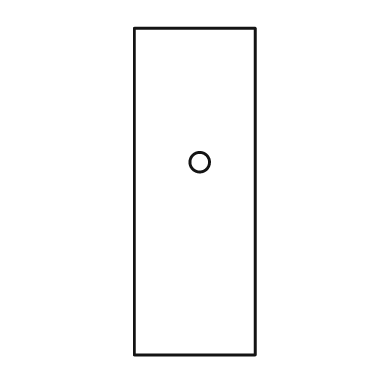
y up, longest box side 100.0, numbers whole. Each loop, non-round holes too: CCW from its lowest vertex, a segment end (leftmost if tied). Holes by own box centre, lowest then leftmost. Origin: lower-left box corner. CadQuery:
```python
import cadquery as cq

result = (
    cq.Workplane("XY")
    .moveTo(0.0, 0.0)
    .lineTo(37.0, 0.0)
    .lineTo(37.0, 100.0)
    .lineTo(0.0, 100.0)
    .close()
    .moveTo(20.0, 59.0)
    .circle(3.0)
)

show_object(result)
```